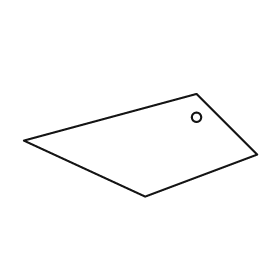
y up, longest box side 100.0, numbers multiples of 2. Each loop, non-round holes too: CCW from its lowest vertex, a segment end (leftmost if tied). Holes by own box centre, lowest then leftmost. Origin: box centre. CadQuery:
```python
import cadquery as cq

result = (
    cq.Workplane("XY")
    .moveTo(2.0, -22.0)
    .lineTo(50.0, -4.0)
    .lineTo(24.0, 22.0)
    .lineTo(-50.0, 2.0)
    .close()
    .moveTo(24.0, 12.0)
    .circle(2.0)
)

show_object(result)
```